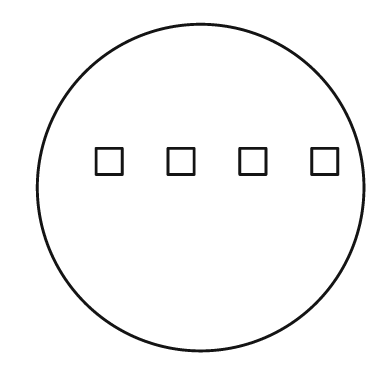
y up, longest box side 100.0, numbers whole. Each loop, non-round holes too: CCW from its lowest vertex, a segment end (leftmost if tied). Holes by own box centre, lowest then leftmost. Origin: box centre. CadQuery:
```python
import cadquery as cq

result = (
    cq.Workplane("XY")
    .moveTo(0.0, 0.0)
    .circle(50.0)
    .moveTo(-32.0, 4.0)
    .lineTo(-24.0, 4.0)
    .lineTo(-24.0, 12.0)
    .lineTo(-32.0, 12.0)
    .close()
    .moveTo(-10.0, 4.0)
    .lineTo(-2.0, 4.0)
    .lineTo(-2.0, 12.0)
    .lineTo(-10.0, 12.0)
    .close()
    .moveTo(12.0, 4.0)
    .lineTo(20.0, 4.0)
    .lineTo(20.0, 12.0)
    .lineTo(12.0, 12.0)
    .close()
    .moveTo(34.0, 4.0)
    .lineTo(42.0, 4.0)
    .lineTo(42.0, 12.0)
    .lineTo(34.0, 12.0)
    .close()
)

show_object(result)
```